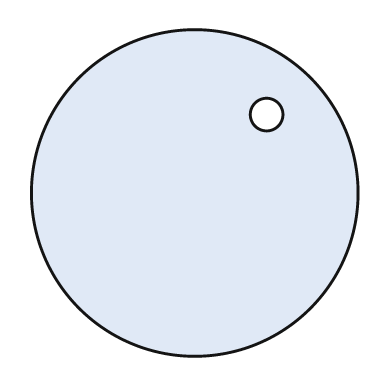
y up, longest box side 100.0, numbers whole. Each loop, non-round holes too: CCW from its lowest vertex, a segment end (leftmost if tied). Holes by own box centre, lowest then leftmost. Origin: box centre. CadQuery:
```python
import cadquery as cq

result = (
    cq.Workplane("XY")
    .moveTo(0.0, 0.0)
    .circle(50.0)
    .moveTo(22.0, 24.0)
    .circle(5.0)
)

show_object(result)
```